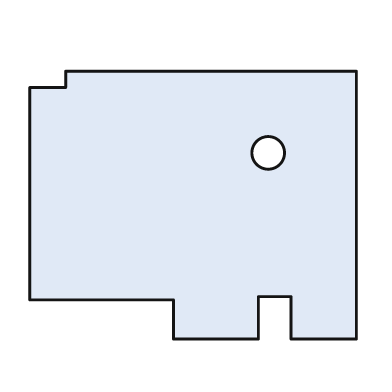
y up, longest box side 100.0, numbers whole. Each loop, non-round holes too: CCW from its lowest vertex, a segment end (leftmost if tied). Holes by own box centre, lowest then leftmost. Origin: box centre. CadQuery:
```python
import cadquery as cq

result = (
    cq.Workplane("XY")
    .moveTo(-6.0, -41.0)
    .lineTo(20.0, -41.0)
    .lineTo(20.0, -28.0)
    .lineTo(30.0, -28.0)
    .lineTo(30.0, -41.0)
    .lineTo(50.0, -41.0)
    .lineTo(50.0, 41.0)
    .lineTo(-39.0, 41.0)
    .lineTo(-39.0, 36.0)
    .lineTo(-50.0, 36.0)
    .lineTo(-50.0, -29.0)
    .lineTo(-6.0, -29.0)
    .close()
    .moveTo(23.0, 16.0)
    .circle(5.0)
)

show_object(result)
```